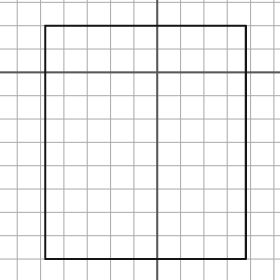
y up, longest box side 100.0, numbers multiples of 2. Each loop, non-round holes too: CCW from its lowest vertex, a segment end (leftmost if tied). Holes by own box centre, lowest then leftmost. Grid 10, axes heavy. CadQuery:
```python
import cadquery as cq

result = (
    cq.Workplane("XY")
    .moveTo(-48.0, -80.0)
    .lineTo(38.0, -80.0)
    .lineTo(38.0, 20.0)
    .lineTo(-48.0, 20.0)
    .close()
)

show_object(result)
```